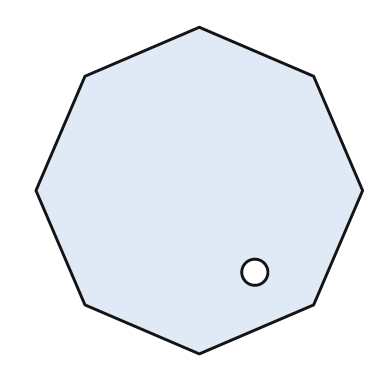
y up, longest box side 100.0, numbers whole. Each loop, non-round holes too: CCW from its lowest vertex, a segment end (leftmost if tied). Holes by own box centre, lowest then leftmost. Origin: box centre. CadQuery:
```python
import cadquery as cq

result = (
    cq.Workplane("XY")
    .moveTo(0.0, -50.0)
    .lineTo(35.0, -35.0)
    .lineTo(50.0, 0.0)
    .lineTo(35.0, 35.0)
    .lineTo(0.0, 50.0)
    .lineTo(-35.0, 35.0)
    .lineTo(-50.0, 0.0)
    .lineTo(-35.0, -35.0)
    .close()
    .moveTo(17.0, -25.0)
    .circle(4.0)
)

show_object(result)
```